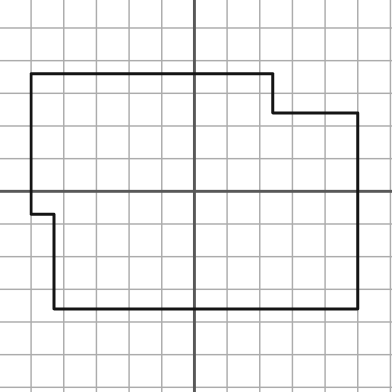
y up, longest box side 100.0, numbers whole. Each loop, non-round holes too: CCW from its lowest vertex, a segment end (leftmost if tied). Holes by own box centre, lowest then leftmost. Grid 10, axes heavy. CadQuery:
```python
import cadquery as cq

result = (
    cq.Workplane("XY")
    .moveTo(-43.0, -36.0)
    .lineTo(50.0, -36.0)
    .lineTo(50.0, 24.0)
    .lineTo(24.0, 24.0)
    .lineTo(24.0, 36.0)
    .lineTo(-50.0, 36.0)
    .lineTo(-50.0, -7.0)
    .lineTo(-43.0, -7.0)
    .close()
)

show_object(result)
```